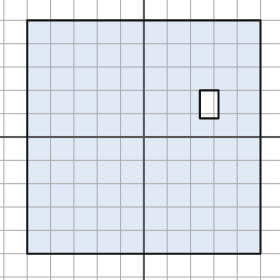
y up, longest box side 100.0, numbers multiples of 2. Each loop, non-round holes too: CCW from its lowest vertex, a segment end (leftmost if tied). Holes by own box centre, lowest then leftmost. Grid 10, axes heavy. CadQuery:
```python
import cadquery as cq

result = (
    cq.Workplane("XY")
    .moveTo(-50.0, -50.0)
    .lineTo(50.0, -50.0)
    .lineTo(50.0, 50.0)
    .lineTo(-50.0, 50.0)
    .close()
    .moveTo(24.0, 8.0)
    .lineTo(32.0, 8.0)
    .lineTo(32.0, 20.0)
    .lineTo(24.0, 20.0)
    .close()
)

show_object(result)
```